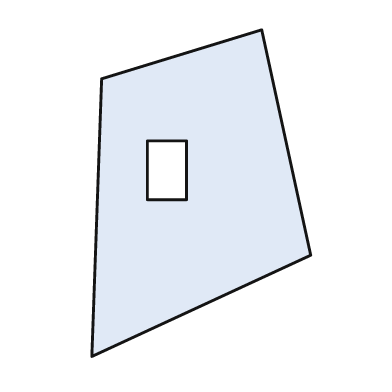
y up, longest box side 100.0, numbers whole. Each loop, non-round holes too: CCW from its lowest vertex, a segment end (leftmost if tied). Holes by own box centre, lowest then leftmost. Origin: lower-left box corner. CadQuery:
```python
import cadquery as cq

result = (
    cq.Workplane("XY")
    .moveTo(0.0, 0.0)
    .lineTo(67.0, 31.0)
    .lineTo(52.0, 100.0)
    .lineTo(3.0, 85.0)
    .close()
    .moveTo(17.0, 48.0)
    .lineTo(29.0, 48.0)
    .lineTo(29.0, 66.0)
    .lineTo(17.0, 66.0)
    .close()
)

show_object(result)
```